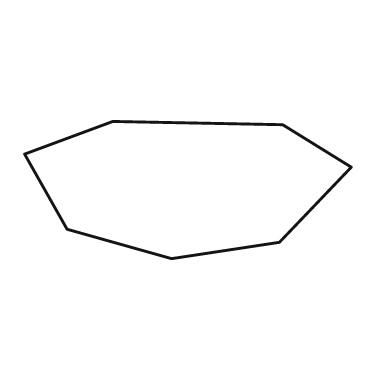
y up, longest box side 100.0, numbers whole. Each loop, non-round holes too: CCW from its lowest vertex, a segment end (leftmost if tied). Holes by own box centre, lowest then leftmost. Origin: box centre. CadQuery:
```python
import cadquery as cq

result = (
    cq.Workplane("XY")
    .moveTo(-5.0, -21.0)
    .lineTo(28.0, -16.0)
    .lineTo(50.0, 7.0)
    .lineTo(29.0, 20.0)
    .lineTo(-23.0, 21.0)
    .lineTo(-50.0, 11.0)
    .lineTo(-37.0, -12.0)
    .close()
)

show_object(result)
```